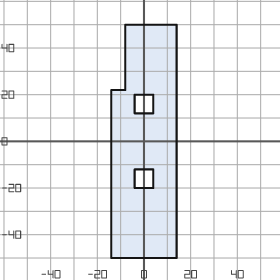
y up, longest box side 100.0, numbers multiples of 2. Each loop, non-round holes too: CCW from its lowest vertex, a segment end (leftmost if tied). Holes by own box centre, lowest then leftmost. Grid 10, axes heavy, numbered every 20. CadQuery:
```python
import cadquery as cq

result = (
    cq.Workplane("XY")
    .moveTo(-14.0, -50.0)
    .lineTo(14.0, -50.0)
    .lineTo(14.0, 50.0)
    .lineTo(-8.0, 50.0)
    .lineTo(-8.0, 22.0)
    .lineTo(-14.0, 22.0)
    .close()
    .moveTo(-4.0, -20.0)
    .lineTo(4.0, -20.0)
    .lineTo(4.0, -12.0)
    .lineTo(-4.0, -12.0)
    .close()
    .moveTo(-4.0, 12.0)
    .lineTo(4.0, 12.0)
    .lineTo(4.0, 20.0)
    .lineTo(-4.0, 20.0)
    .close()
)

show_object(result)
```